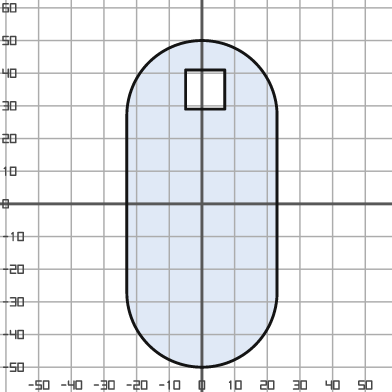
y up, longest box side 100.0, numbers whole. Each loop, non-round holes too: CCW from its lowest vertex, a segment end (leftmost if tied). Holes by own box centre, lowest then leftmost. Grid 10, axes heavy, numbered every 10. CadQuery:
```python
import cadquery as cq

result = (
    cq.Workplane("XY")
    .moveTo(-23.0, -27.0)
    .threePointArc((0.0, -50.0), (23.0, -27.0))
    .lineTo(23.0, 27.0)
    .threePointArc((0.0, 50.0), (-23.0, 27.0))
    .close()
    .moveTo(-5.0, 29.0)
    .lineTo(7.0, 29.0)
    .lineTo(7.0, 41.0)
    .lineTo(-5.0, 41.0)
    .close()
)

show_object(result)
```